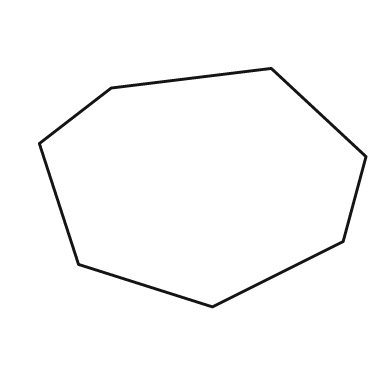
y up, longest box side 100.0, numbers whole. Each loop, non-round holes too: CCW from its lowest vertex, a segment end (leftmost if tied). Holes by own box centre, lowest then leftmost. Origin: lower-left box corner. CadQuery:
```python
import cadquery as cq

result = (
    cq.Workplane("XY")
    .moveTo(53.0, 0.0)
    .lineTo(93.0, 20.0)
    .lineTo(100.0, 46.0)
    .lineTo(71.0, 73.0)
    .lineTo(22.0, 67.0)
    .lineTo(0.0, 50.0)
    .lineTo(12.0, 13.0)
    .close()
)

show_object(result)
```